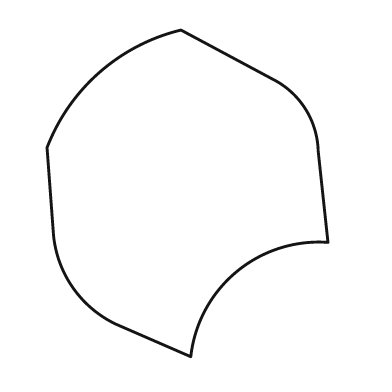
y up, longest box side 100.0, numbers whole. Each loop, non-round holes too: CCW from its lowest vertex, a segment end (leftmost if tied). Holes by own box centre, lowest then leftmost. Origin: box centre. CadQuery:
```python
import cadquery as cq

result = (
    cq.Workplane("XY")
    .moveTo(1.0, -50.0)
    .threePointArc((15.0, -24.0), (43.0, -15.0))
    .lineTo(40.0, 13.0)
    .threePointArc((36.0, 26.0), (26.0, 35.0))
    .lineTo(-2.0, 50.0)
    .threePointArc((-27.0, 37.0), (-43.0, 14.0))
    .lineTo(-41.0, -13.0)
    .threePointArc((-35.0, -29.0), (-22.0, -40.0))
    .close()
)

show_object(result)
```